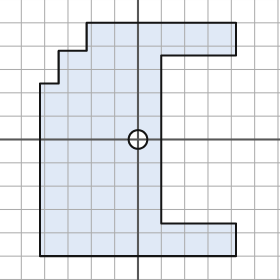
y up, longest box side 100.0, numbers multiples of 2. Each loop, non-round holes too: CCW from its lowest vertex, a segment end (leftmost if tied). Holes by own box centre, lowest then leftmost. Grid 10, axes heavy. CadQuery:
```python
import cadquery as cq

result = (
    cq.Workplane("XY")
    .moveTo(-42.0, -50.0)
    .lineTo(42.0, -50.0)
    .lineTo(42.0, -36.0)
    .lineTo(10.0, -36.0)
    .lineTo(10.0, 36.0)
    .lineTo(42.0, 36.0)
    .lineTo(42.0, 50.0)
    .lineTo(-22.0, 50.0)
    .lineTo(-22.0, 38.0)
    .lineTo(-34.0, 38.0)
    .lineTo(-34.0, 24.0)
    .lineTo(-42.0, 24.0)
    .close()
    .moveTo(0.0, 0.0)
    .circle(4.0)
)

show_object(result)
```